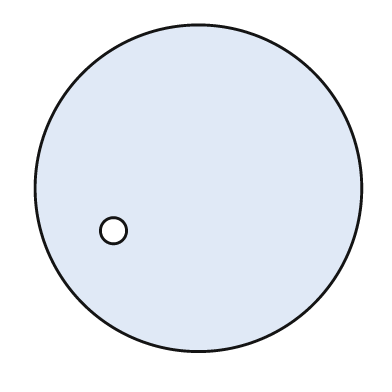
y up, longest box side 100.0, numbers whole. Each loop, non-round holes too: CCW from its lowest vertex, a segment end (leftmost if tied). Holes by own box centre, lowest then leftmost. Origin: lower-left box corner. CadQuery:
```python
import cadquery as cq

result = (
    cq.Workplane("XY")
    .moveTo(50.0, 50.0)
    .circle(50.0)
    .moveTo(24.0, 37.0)
    .circle(4.0)
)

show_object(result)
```